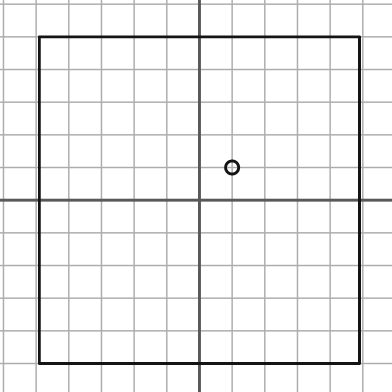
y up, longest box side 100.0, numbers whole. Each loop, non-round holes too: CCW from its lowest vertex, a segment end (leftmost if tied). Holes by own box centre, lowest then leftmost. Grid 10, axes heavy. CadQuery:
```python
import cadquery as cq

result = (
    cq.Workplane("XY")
    .moveTo(-49.0, -50.0)
    .lineTo(49.0, -50.0)
    .lineTo(49.0, 50.0)
    .lineTo(-49.0, 50.0)
    .close()
    .moveTo(10.0, 10.0)
    .circle(2.0)
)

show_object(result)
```